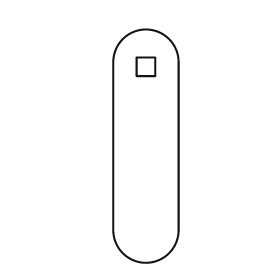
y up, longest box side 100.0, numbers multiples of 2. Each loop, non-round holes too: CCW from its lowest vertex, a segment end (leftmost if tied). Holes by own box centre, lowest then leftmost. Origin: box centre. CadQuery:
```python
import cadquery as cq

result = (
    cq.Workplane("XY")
    .moveTo(-14.0, -36.0)
    .threePointArc((0.0, -50.0), (14.0, -36.0))
    .lineTo(14.0, 36.0)
    .threePointArc((0.0, 50.0), (-14.0, 36.0))
    .close()
    .moveTo(-4.0, 30.0)
    .lineTo(4.0, 30.0)
    .lineTo(4.0, 38.0)
    .lineTo(-4.0, 38.0)
    .close()
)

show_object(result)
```